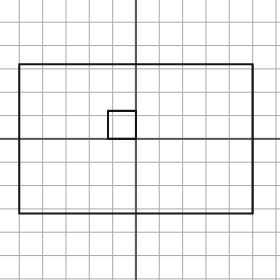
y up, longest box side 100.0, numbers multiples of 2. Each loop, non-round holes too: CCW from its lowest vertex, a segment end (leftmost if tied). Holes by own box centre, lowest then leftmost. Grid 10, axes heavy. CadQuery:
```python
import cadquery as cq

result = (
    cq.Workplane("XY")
    .moveTo(-50.0, -32.0)
    .lineTo(50.0, -32.0)
    .lineTo(50.0, 32.0)
    .lineTo(-50.0, 32.0)
    .close()
    .moveTo(-12.0, 0.0)
    .lineTo(0.0, 0.0)
    .lineTo(0.0, 12.0)
    .lineTo(-12.0, 12.0)
    .close()
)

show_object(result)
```